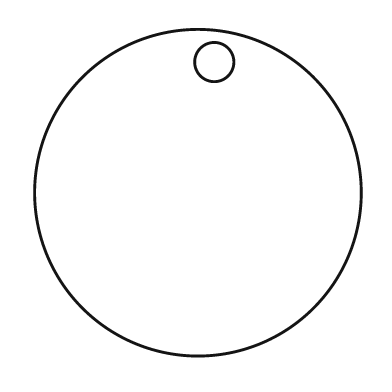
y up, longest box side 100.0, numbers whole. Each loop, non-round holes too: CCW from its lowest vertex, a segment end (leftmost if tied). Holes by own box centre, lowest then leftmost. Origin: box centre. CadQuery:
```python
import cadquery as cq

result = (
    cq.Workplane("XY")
    .moveTo(0.0, 0.0)
    .circle(50.0)
    .moveTo(5.0, 40.0)
    .circle(6.0)
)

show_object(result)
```